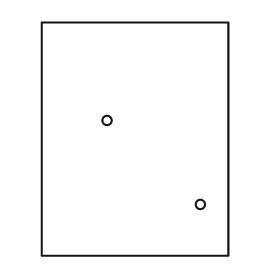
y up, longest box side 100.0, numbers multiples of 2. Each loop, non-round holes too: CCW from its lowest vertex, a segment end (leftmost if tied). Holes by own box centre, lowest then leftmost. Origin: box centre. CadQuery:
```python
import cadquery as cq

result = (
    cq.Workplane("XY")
    .moveTo(-40.0, -50.0)
    .lineTo(40.0, -50.0)
    .lineTo(40.0, 50.0)
    .lineTo(-40.0, 50.0)
    .close()
    .moveTo(28.0, -28.0)
    .circle(2.0)
    .moveTo(-12.0, 8.0)
    .circle(2.0)
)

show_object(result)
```